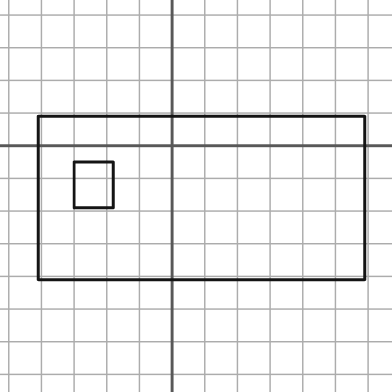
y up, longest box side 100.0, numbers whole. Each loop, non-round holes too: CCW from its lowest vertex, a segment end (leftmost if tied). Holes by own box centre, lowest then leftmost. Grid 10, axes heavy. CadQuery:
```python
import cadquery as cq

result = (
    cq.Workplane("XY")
    .moveTo(-41.0, -41.0)
    .lineTo(59.0, -41.0)
    .lineTo(59.0, 9.0)
    .lineTo(-41.0, 9.0)
    .close()
    .moveTo(-30.0, -19.0)
    .lineTo(-18.0, -19.0)
    .lineTo(-18.0, -5.0)
    .lineTo(-30.0, -5.0)
    .close()
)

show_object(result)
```